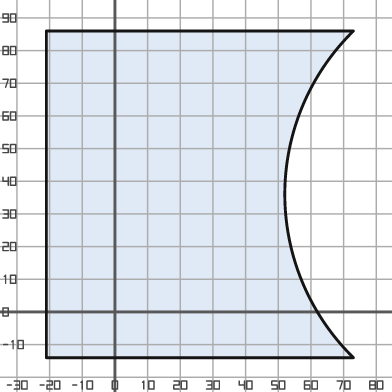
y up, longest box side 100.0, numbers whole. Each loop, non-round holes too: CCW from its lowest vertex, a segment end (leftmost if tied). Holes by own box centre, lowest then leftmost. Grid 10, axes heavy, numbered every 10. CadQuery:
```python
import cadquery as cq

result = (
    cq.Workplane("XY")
    .moveTo(-21.0, -14.0)
    .lineTo(73.0, -14.0)
    .threePointArc((52.0, 36.0), (73.0, 86.0))
    .lineTo(-21.0, 86.0)
    .close()
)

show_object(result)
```